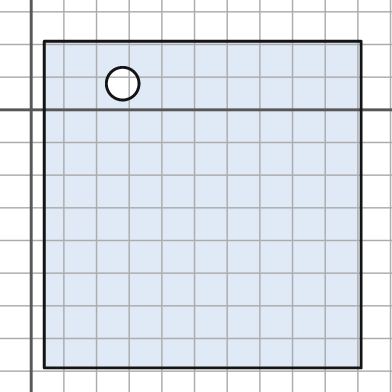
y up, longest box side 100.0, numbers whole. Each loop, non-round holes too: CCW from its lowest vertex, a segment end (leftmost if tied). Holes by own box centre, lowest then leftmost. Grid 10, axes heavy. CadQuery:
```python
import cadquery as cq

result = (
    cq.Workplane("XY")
    .moveTo(4.0, -79.0)
    .lineTo(101.0, -79.0)
    .lineTo(101.0, 21.0)
    .lineTo(4.0, 21.0)
    .close()
    .moveTo(28.0, 8.0)
    .circle(5.0)
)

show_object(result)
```